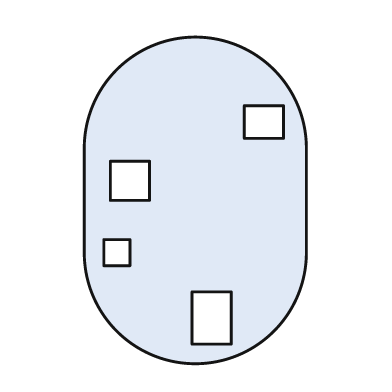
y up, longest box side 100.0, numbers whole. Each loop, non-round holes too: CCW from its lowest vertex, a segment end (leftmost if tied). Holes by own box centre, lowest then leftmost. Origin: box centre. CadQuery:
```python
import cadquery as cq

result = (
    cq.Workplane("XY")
    .moveTo(-34.0, -16.0)
    .threePointArc((0.0, -50.0), (34.0, -16.0))
    .lineTo(34.0, 16.0)
    .threePointArc((0.0, 50.0), (-34.0, 16.0))
    .close()
    .moveTo(-1.0, -44.0)
    .lineTo(11.0, -44.0)
    .lineTo(11.0, -28.0)
    .lineTo(-1.0, -28.0)
    .close()
    .moveTo(-28.0, -20.0)
    .lineTo(-20.0, -20.0)
    .lineTo(-20.0, -12.0)
    .lineTo(-28.0, -12.0)
    .close()
    .moveTo(-26.0, 0.0)
    .lineTo(-14.0, 0.0)
    .lineTo(-14.0, 12.0)
    .lineTo(-26.0, 12.0)
    .close()
    .moveTo(15.0, 19.0)
    .lineTo(27.0, 19.0)
    .lineTo(27.0, 29.0)
    .lineTo(15.0, 29.0)
    .close()
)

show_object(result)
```